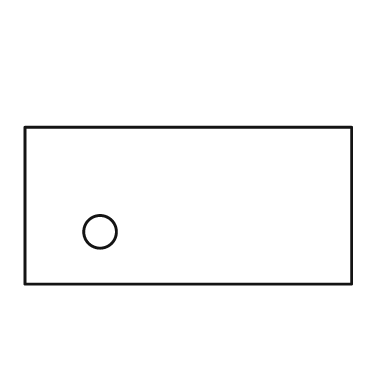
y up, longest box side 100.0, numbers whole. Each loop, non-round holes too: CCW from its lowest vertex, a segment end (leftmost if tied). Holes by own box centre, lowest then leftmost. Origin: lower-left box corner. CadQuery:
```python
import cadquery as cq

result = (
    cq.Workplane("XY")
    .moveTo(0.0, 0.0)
    .lineTo(100.0, 0.0)
    .lineTo(100.0, 48.0)
    .lineTo(0.0, 48.0)
    .close()
    .moveTo(23.0, 16.0)
    .circle(5.0)
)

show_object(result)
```